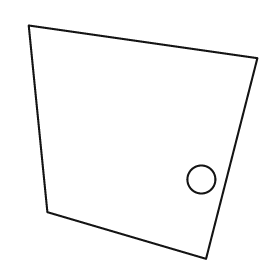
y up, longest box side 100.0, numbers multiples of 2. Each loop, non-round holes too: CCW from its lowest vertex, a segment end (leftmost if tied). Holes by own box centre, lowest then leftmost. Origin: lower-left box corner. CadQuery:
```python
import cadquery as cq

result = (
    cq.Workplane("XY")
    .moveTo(76.0, 0.0)
    .lineTo(98.0, 86.0)
    .lineTo(0.0, 100.0)
    .lineTo(8.0, 20.0)
    .close()
    .moveTo(74.0, 34.0)
    .circle(6.0)
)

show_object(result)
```